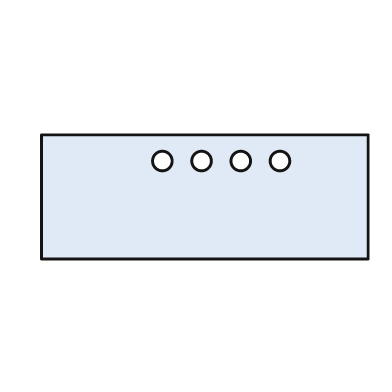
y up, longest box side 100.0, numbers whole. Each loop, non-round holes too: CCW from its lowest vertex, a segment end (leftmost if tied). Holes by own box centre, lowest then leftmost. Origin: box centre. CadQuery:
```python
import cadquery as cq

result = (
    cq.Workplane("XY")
    .moveTo(-50.0, -19.0)
    .lineTo(50.0, -19.0)
    .lineTo(50.0, 19.0)
    .lineTo(-50.0, 19.0)
    .close()
    .moveTo(-13.0, 11.0)
    .circle(3.0)
    .moveTo(-1.0, 11.0)
    .circle(3.0)
    .moveTo(11.0, 11.0)
    .circle(3.0)
    .moveTo(23.0, 11.0)
    .circle(3.0)
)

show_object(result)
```